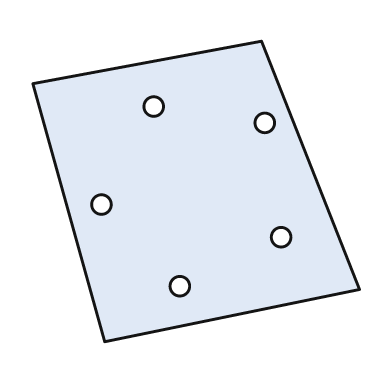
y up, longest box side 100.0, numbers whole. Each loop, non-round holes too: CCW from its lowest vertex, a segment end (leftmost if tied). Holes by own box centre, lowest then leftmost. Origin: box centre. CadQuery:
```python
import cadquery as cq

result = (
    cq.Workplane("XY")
    .moveTo(-28.0, -46.0)
    .lineTo(50.0, -30.0)
    .lineTo(20.0, 46.0)
    .lineTo(-50.0, 33.0)
    .close()
    .moveTo(-5.0, -29.0)
    .circle(3.0)
    .moveTo(26.0, -14.0)
    .circle(3.0)
    .moveTo(-29.0, -4.0)
    .circle(3.0)
    .moveTo(21.0, 21.0)
    .circle(3.0)
    .moveTo(-13.0, 26.0)
    .circle(3.0)
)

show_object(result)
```